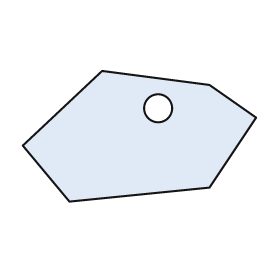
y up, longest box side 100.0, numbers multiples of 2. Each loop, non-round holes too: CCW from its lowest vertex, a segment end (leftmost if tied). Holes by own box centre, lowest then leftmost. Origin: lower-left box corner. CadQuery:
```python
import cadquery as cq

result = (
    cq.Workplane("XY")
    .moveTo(20.0, 0.0)
    .lineTo(80.0, 6.0)
    .lineTo(100.0, 36.0)
    .lineTo(80.0, 50.0)
    .lineTo(34.0, 56.0)
    .lineTo(0.0, 24.0)
    .close()
    .moveTo(58.0, 40.0)
    .circle(6.0)
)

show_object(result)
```